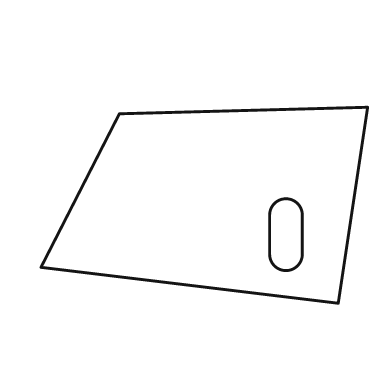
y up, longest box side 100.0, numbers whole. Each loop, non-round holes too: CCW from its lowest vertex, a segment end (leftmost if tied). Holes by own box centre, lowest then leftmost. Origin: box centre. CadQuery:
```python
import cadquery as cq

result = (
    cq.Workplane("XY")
    .moveTo(41.0, -30.0)
    .lineTo(50.0, 30.0)
    .lineTo(-26.0, 28.0)
    .lineTo(-50.0, -19.0)
    .close()
    .moveTo(20.0, -15.0)
    .threePointArc((25.0, -20.0), (30.0, -15.0))
    .lineTo(30.0, -3.0)
    .threePointArc((25.0, 2.0), (20.0, -3.0))
    .close()
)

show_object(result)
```